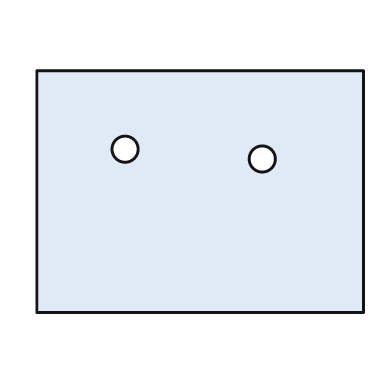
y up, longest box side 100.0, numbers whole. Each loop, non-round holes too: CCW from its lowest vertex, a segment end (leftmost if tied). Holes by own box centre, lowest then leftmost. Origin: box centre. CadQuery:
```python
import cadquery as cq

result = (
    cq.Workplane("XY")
    .moveTo(-50.0, -37.0)
    .lineTo(50.0, -37.0)
    .lineTo(50.0, 37.0)
    .lineTo(-50.0, 37.0)
    .close()
    .moveTo(19.0, 10.0)
    .circle(4.0)
    .moveTo(-23.0, 13.0)
    .circle(4.0)
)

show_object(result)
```